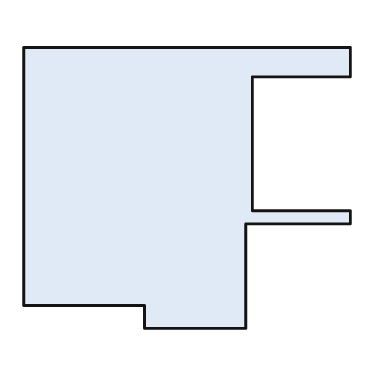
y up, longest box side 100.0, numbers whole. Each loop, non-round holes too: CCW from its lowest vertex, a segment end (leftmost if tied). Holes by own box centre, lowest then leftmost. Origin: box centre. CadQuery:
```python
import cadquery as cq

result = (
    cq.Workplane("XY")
    .moveTo(-13.0, -43.0)
    .lineTo(18.0, -43.0)
    .lineTo(18.0, -11.0)
    .lineTo(50.0, -11.0)
    .lineTo(50.0, -7.0)
    .lineTo(20.0, -7.0)
    .lineTo(20.0, 34.0)
    .lineTo(50.0, 34.0)
    .lineTo(50.0, 43.0)
    .lineTo(-50.0, 43.0)
    .lineTo(-50.0, -36.0)
    .lineTo(-13.0, -36.0)
    .close()
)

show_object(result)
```